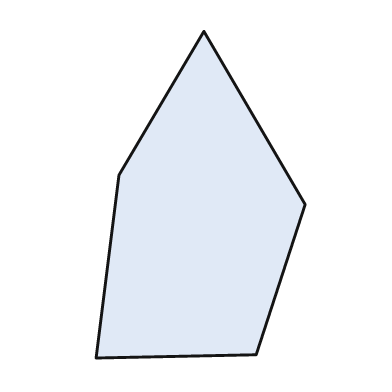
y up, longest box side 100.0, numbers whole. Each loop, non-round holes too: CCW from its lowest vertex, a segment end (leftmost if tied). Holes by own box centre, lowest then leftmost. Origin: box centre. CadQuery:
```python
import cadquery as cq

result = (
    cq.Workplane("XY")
    .moveTo(-32.0, -50.0)
    .lineTo(17.0, -49.0)
    .lineTo(32.0, -3.0)
    .lineTo(1.0, 50.0)
    .lineTo(-25.0, 6.0)
    .close()
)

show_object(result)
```